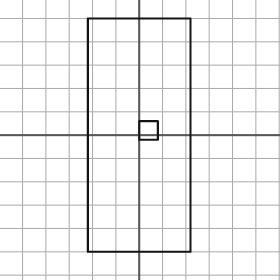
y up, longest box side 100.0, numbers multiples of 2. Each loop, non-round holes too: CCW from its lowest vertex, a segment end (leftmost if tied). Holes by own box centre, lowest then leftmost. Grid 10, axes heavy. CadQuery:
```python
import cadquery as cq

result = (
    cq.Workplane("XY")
    .moveTo(-22.0, -50.0)
    .lineTo(22.0, -50.0)
    .lineTo(22.0, 50.0)
    .lineTo(-22.0, 50.0)
    .close()
    .moveTo(0.0, -2.0)
    .lineTo(8.0, -2.0)
    .lineTo(8.0, 6.0)
    .lineTo(0.0, 6.0)
    .close()
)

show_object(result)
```